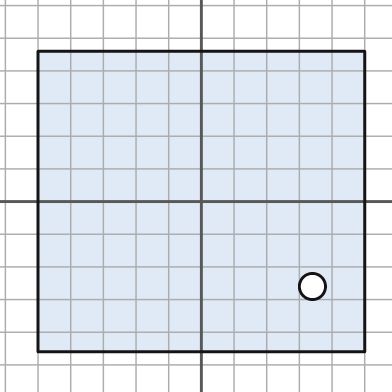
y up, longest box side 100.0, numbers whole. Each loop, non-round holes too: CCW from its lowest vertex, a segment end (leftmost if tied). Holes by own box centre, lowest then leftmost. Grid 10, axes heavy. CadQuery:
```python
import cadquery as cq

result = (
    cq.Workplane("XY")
    .moveTo(-50.0, -46.0)
    .lineTo(50.0, -46.0)
    .lineTo(50.0, 46.0)
    .lineTo(-50.0, 46.0)
    .close()
    .moveTo(34.0, -26.0)
    .circle(4.0)
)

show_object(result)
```